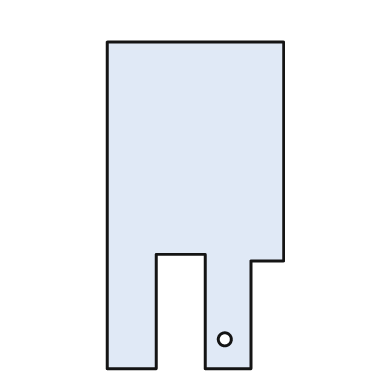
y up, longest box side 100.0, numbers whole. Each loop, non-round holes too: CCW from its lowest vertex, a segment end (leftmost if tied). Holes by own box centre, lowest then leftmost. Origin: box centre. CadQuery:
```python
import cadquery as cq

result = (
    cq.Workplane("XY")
    .moveTo(-27.0, -50.0)
    .lineTo(-12.0, -50.0)
    .lineTo(-12.0, -15.0)
    .lineTo(3.0, -15.0)
    .lineTo(3.0, -50.0)
    .lineTo(17.0, -50.0)
    .lineTo(17.0, -17.0)
    .lineTo(27.0, -17.0)
    .lineTo(27.0, 50.0)
    .lineTo(-27.0, 50.0)
    .close()
    .moveTo(9.0, -41.0)
    .circle(2.0)
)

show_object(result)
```